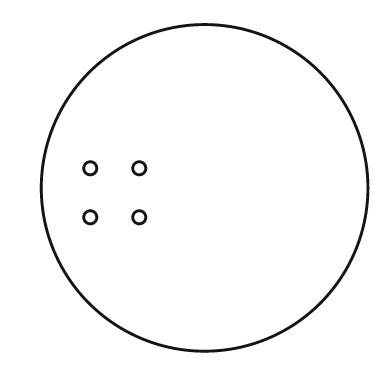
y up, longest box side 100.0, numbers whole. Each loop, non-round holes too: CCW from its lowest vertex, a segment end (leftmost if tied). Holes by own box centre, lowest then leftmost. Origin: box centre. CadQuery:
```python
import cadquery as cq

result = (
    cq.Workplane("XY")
    .moveTo(0.0, 0.0)
    .circle(50.0)
    .moveTo(-35.0, -9.0)
    .circle(2.0)
    .moveTo(-20.0, -9.0)
    .circle(2.0)
    .moveTo(-35.0, 6.0)
    .circle(2.0)
    .moveTo(-20.0, 6.0)
    .circle(2.0)
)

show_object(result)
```